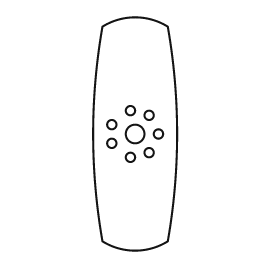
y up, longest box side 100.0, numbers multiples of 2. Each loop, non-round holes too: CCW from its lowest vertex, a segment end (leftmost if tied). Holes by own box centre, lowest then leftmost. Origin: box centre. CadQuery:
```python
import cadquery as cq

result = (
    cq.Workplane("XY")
    .moveTo(-14.0, -46.0)
    .threePointArc((0.0, -50.0), (14.0, -46.0))
    .threePointArc((18.0, 0.0), (14.0, 46.0))
    .threePointArc((0.0, 50.0), (-14.0, 46.0))
    .threePointArc((-18.0, 0.0), (-14.0, -46.0))
    .close()
    .moveTo(-2.0, -10.0)
    .circle(2.0)
    .moveTo(6.0, -8.0)
    .circle(2.0)
    .moveTo(-10.0, -4.0)
    .circle(2.0)
    .moveTo(0.0, 0.0)
    .circle(4.0)
    .moveTo(10.0, 0.0)
    .circle(2.0)
    .moveTo(-10.0, 4.0)
    .circle(2.0)
    .moveTo(6.0, 8.0)
    .circle(2.0)
    .moveTo(-2.0, 10.0)
    .circle(2.0)
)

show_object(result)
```